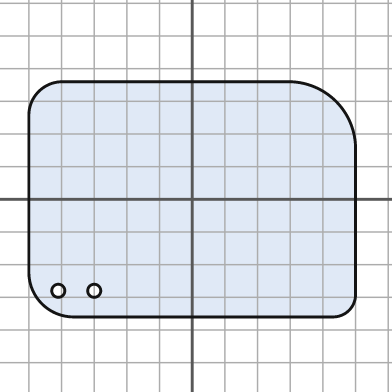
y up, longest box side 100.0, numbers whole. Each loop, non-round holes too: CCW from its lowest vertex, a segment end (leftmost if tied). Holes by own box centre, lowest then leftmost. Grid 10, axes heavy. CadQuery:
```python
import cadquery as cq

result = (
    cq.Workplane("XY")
    .moveTo(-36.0, -36.0)
    .lineTo(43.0, -36.0)
    .threePointArc((48.0, -34.0), (50.0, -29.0))
    .lineTo(50.0, 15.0)
    .threePointArc((44.0, 30.0), (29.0, 36.0))
    .lineTo(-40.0, 36.0)
    .threePointArc((-47.0, 33.0), (-50.0, 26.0))
    .lineTo(-50.0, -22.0)
    .threePointArc((-46.0, -32.0), (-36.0, -36.0))
    .close()
    .moveTo(-41.0, -28.0)
    .circle(2.0)
    .moveTo(-30.0, -28.0)
    .circle(2.0)
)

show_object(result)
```